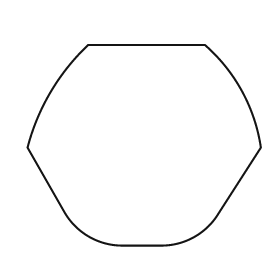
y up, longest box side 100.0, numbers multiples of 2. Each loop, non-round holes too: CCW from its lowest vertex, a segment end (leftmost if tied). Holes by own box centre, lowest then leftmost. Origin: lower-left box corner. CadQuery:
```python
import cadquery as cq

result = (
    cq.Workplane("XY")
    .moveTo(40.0, 0.0)
    .lineTo(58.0, 0.0)
    .threePointArc((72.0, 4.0), (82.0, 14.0))
    .lineTo(100.0, 42.0)
    .threePointArc((92.0, 66.0), (76.0, 86.0))
    .lineTo(26.0, 86.0)
    .threePointArc((10.0, 66.0), (0.0, 42.0))
    .lineTo(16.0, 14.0)
    .threePointArc((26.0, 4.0), (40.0, 0.0))
    .close()
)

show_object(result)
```